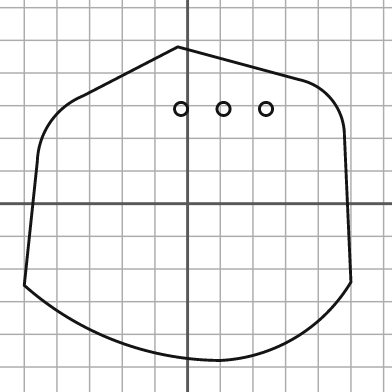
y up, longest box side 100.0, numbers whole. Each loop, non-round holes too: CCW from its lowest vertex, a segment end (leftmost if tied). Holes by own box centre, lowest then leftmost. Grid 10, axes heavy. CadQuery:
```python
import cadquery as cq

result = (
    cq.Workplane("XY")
    .moveTo(10.0, -48.0)
    .threePointArc((33.0, -41.0), (50.0, -24.0))
    .lineTo(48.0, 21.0)
    .threePointArc((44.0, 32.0), (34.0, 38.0))
    .lineTo(-3.0, 48.0)
    .lineTo(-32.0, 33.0)
    .threePointArc((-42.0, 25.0), (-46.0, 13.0))
    .lineTo(-50.0, -25.0)
    .threePointArc((-22.0, -42.0), (10.0, -48.0))
    .close()
    .moveTo(-2.0, 29.0)
    .circle(2.0)
    .moveTo(11.0, 29.0)
    .circle(2.0)
    .moveTo(24.0, 29.0)
    .circle(2.0)
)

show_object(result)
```